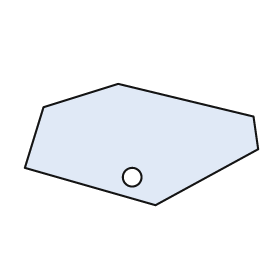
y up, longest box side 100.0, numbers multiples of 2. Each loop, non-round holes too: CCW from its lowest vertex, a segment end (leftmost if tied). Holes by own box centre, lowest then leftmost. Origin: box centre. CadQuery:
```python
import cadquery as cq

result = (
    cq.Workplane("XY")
    .moveTo(6.0, -26.0)
    .lineTo(50.0, -2.0)
    .lineTo(48.0, 12.0)
    .lineTo(-10.0, 26.0)
    .lineTo(-42.0, 16.0)
    .lineTo(-50.0, -10.0)
    .close()
    .moveTo(-4.0, -14.0)
    .circle(4.0)
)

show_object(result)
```